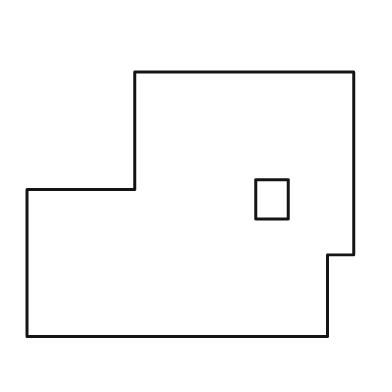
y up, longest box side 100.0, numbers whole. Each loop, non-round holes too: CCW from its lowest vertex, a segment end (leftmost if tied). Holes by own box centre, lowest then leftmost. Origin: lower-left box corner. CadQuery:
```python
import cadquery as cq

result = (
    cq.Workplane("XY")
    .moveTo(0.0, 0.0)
    .lineTo(92.0, 0.0)
    .lineTo(92.0, 25.0)
    .lineTo(100.0, 25.0)
    .lineTo(100.0, 81.0)
    .lineTo(33.0, 81.0)
    .lineTo(33.0, 45.0)
    .lineTo(0.0, 45.0)
    .close()
    .moveTo(70.0, 36.0)
    .lineTo(80.0, 36.0)
    .lineTo(80.0, 48.0)
    .lineTo(70.0, 48.0)
    .close()
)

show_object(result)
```